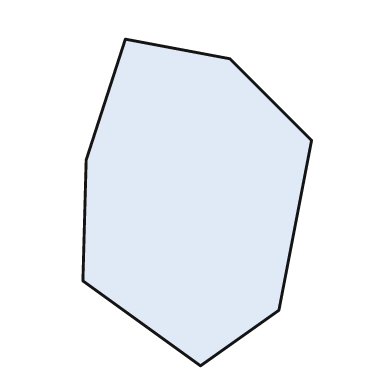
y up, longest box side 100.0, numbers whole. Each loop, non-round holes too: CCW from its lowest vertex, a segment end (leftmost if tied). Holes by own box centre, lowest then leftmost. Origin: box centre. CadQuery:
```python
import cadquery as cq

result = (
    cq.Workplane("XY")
    .moveTo(1.0, -50.0)
    .lineTo(25.0, -33.0)
    .lineTo(35.0, 19.0)
    .lineTo(10.0, 44.0)
    .lineTo(-22.0, 50.0)
    .lineTo(-34.0, 13.0)
    .lineTo(-35.0, -24.0)
    .close()
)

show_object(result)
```